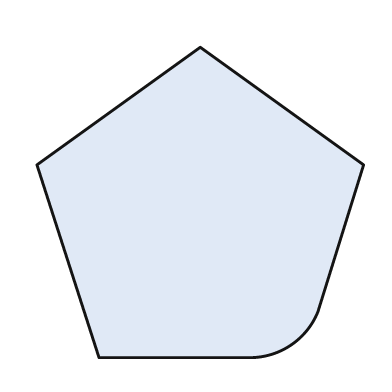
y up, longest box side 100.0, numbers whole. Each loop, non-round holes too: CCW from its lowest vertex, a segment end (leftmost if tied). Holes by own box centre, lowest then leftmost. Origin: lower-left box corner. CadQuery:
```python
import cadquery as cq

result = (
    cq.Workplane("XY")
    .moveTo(19.0, 0.0)
    .lineTo(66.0, 0.0)
    .threePointArc((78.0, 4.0), (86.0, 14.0))
    .lineTo(100.0, 59.0)
    .lineTo(50.0, 95.0)
    .lineTo(0.0, 59.0)
    .close()
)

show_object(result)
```